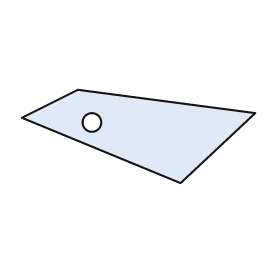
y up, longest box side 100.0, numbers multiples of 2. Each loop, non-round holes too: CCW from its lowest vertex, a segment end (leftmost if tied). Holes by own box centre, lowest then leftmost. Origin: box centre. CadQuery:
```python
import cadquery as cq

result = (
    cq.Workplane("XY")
    .moveTo(18.0, -20.0)
    .lineTo(50.0, 10.0)
    .lineTo(-26.0, 20.0)
    .lineTo(-50.0, 8.0)
    .close()
    .moveTo(-20.0, 6.0)
    .circle(4.0)
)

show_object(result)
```